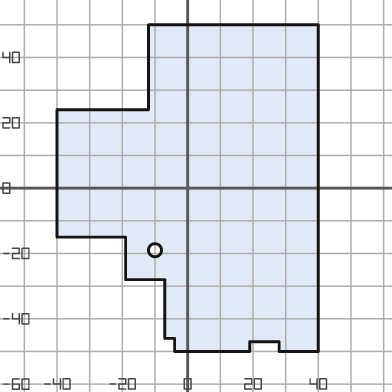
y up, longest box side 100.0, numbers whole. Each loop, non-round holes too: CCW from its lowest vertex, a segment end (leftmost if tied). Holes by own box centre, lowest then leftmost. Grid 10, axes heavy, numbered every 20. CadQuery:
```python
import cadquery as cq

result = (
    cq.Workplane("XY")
    .moveTo(-4.0, -50.0)
    .lineTo(19.0, -50.0)
    .lineTo(19.0, -47.0)
    .lineTo(28.0, -47.0)
    .lineTo(28.0, -50.0)
    .lineTo(40.0, -50.0)
    .lineTo(40.0, 50.0)
    .lineTo(-12.0, 50.0)
    .lineTo(-12.0, 24.0)
    .lineTo(-40.0, 24.0)
    .lineTo(-40.0, -15.0)
    .lineTo(-19.0, -15.0)
    .lineTo(-19.0, -28.0)
    .lineTo(-7.0, -28.0)
    .lineTo(-7.0, -46.0)
    .lineTo(-4.0, -46.0)
    .close()
    .moveTo(-10.0, -19.0)
    .circle(2.0)
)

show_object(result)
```